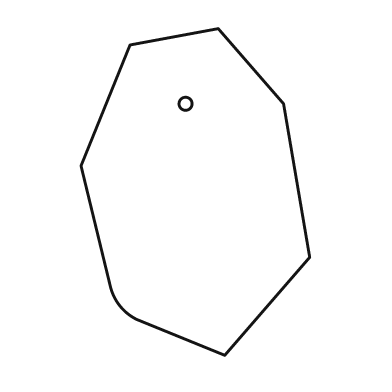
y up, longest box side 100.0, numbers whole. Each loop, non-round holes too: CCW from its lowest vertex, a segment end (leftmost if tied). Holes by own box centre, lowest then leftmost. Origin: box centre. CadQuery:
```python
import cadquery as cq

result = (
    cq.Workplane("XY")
    .moveTo(9.0, -50.0)
    .lineTo(35.0, -20.0)
    .lineTo(27.0, 27.0)
    .lineTo(7.0, 50.0)
    .lineTo(-20.0, 45.0)
    .lineTo(-35.0, 8.0)
    .lineTo(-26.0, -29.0)
    .threePointArc((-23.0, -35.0), (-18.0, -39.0))
    .close()
    .moveTo(-3.0, 27.0)
    .circle(2.0)
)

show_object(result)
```